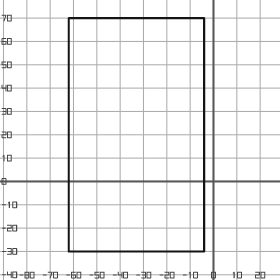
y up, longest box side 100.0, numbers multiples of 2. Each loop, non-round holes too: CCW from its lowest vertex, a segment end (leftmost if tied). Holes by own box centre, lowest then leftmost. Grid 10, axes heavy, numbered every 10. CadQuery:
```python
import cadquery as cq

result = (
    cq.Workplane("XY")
    .moveTo(-62.0, -30.0)
    .lineTo(-4.0, -30.0)
    .lineTo(-4.0, 70.0)
    .lineTo(-62.0, 70.0)
    .close()
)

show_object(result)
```